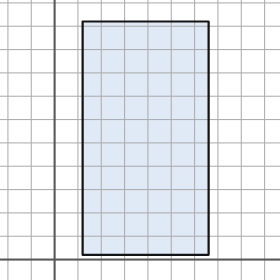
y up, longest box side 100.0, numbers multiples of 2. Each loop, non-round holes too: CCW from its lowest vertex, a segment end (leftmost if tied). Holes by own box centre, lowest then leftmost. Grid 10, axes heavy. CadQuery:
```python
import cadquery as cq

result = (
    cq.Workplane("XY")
    .moveTo(12.0, 2.0)
    .lineTo(66.0, 2.0)
    .lineTo(66.0, 102.0)
    .lineTo(12.0, 102.0)
    .close()
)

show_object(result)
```